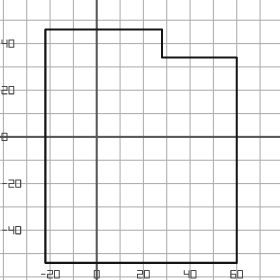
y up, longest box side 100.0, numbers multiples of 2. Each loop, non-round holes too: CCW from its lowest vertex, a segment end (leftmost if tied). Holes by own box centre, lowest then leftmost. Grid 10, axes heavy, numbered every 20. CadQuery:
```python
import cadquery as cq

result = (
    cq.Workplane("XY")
    .moveTo(-22.0, -54.0)
    .lineTo(60.0, -54.0)
    .lineTo(60.0, 34.0)
    .lineTo(28.0, 34.0)
    .lineTo(28.0, 46.0)
    .lineTo(-22.0, 46.0)
    .close()
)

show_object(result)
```